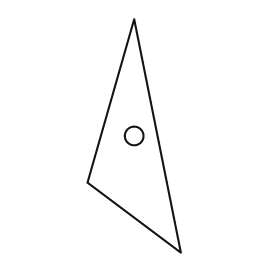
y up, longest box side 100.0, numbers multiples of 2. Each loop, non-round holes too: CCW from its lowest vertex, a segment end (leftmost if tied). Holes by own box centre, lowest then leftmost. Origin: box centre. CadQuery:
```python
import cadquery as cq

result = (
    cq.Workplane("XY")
    .moveTo(20.0, -50.0)
    .lineTo(0.0, 50.0)
    .lineTo(-20.0, -20.0)
    .close()
    .moveTo(0.0, 0.0)
    .circle(4.0)
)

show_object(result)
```